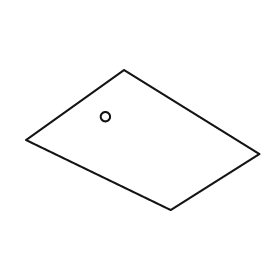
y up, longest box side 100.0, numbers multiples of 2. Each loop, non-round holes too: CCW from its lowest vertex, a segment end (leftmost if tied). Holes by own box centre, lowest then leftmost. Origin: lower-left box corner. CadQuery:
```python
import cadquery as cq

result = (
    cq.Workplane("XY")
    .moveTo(62.0, 0.0)
    .lineTo(100.0, 24.0)
    .lineTo(42.0, 60.0)
    .lineTo(0.0, 30.0)
    .close()
    .moveTo(34.0, 40.0)
    .circle(2.0)
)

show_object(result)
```